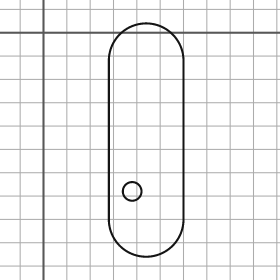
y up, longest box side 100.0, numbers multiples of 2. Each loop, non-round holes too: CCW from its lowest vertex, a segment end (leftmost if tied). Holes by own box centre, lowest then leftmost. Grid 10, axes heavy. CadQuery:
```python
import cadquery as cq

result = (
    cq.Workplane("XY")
    .moveTo(28.0, -80.0)
    .threePointArc((44.0, -96.0), (60.0, -80.0))
    .lineTo(60.0, -12.0)
    .threePointArc((44.0, 4.0), (28.0, -12.0))
    .close()
    .moveTo(38.0, -68.0)
    .circle(4.0)
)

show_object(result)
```